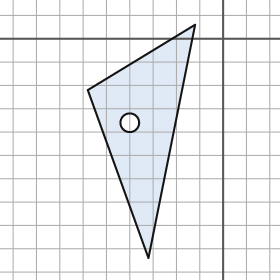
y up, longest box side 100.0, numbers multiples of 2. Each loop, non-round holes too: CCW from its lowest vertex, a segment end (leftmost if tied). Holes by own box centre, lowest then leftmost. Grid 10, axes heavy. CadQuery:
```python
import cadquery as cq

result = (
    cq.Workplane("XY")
    .moveTo(-32.0, -94.0)
    .lineTo(-12.0, 6.0)
    .lineTo(-58.0, -22.0)
    .close()
    .moveTo(-40.0, -36.0)
    .circle(4.0)
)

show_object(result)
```